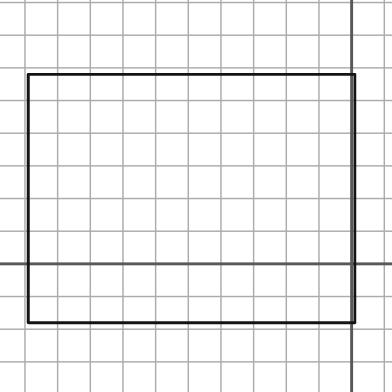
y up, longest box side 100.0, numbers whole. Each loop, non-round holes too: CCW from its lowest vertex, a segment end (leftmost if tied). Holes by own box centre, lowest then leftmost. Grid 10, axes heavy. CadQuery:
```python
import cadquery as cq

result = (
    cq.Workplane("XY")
    .moveTo(-99.0, -18.0)
    .lineTo(1.0, -18.0)
    .lineTo(1.0, 58.0)
    .lineTo(-99.0, 58.0)
    .close()
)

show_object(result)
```